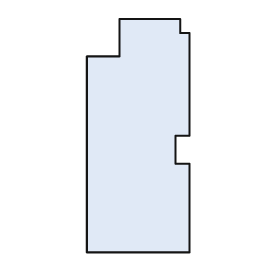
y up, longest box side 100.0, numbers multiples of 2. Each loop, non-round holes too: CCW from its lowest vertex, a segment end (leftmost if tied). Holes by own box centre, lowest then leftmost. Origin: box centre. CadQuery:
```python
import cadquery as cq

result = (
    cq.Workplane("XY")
    .moveTo(-22.0, -50.0)
    .lineTo(22.0, -50.0)
    .lineTo(22.0, -12.0)
    .lineTo(16.0, -12.0)
    .lineTo(16.0, 0.0)
    .lineTo(22.0, 0.0)
    .lineTo(22.0, 44.0)
    .lineTo(18.0, 44.0)
    .lineTo(18.0, 50.0)
    .lineTo(-8.0, 50.0)
    .lineTo(-8.0, 34.0)
    .lineTo(-22.0, 34.0)
    .close()
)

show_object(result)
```